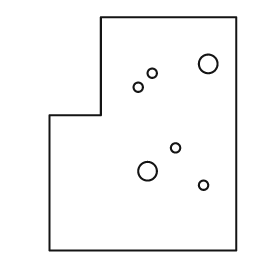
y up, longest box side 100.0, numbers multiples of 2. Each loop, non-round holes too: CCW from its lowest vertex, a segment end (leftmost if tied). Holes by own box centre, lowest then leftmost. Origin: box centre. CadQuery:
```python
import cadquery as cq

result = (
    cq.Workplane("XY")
    .moveTo(-40.0, -50.0)
    .lineTo(40.0, -50.0)
    .lineTo(40.0, 50.0)
    .lineTo(-18.0, 50.0)
    .lineTo(-18.0, 8.0)
    .lineTo(-40.0, 8.0)
    .close()
    .moveTo(26.0, -22.0)
    .circle(2.0)
    .moveTo(2.0, -16.0)
    .circle(4.0)
    .moveTo(14.0, -6.0)
    .circle(2.0)
    .moveTo(-2.0, 20.0)
    .circle(2.0)
    .moveTo(4.0, 26.0)
    .circle(2.0)
    .moveTo(28.0, 30.0)
    .circle(4.0)
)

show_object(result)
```